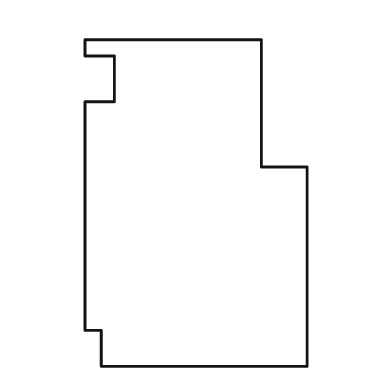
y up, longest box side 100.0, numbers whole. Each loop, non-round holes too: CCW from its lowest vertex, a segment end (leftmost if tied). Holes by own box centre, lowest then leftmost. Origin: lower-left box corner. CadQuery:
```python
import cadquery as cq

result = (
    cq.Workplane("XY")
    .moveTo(5.0, 0.0)
    .lineTo(68.0, 0.0)
    .lineTo(68.0, 61.0)
    .lineTo(54.0, 61.0)
    .lineTo(54.0, 100.0)
    .lineTo(0.0, 100.0)
    .lineTo(0.0, 95.0)
    .lineTo(9.0, 95.0)
    .lineTo(9.0, 81.0)
    .lineTo(0.0, 81.0)
    .lineTo(0.0, 11.0)
    .lineTo(5.0, 11.0)
    .close()
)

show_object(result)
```